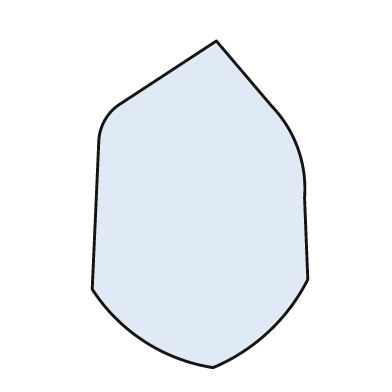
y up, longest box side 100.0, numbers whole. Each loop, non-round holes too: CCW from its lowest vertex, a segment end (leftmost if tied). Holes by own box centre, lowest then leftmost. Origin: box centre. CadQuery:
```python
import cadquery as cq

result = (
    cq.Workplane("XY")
    .moveTo(4.0, -50.0)
    .threePointArc((21.0, -39.0), (33.0, -23.0))
    .lineTo(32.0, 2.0)
    .threePointArc((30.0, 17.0), (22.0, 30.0))
    .lineTo(5.0, 50.0)
    .lineTo(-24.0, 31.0)
    .threePointArc((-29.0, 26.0), (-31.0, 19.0))
    .lineTo(-33.0, -26.0)
    .threePointArc((-17.0, -42.0), (4.0, -50.0))
    .close()
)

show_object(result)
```